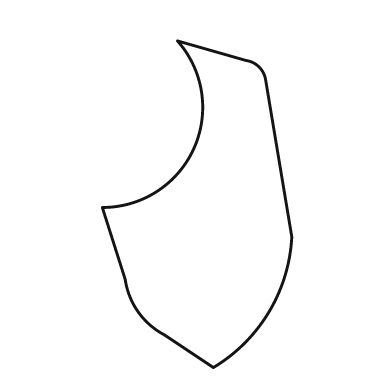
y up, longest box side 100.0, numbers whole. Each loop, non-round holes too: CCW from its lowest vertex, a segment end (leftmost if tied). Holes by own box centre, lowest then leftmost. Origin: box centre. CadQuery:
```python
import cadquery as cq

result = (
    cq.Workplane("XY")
    .moveTo(5.0, -50.0)
    .threePointArc((22.0, -33.0), (29.0, -10.0))
    .lineTo(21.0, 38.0)
    .threePointArc((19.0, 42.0), (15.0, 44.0))
    .lineTo(-6.0, 50.0)
    .threePointArc((-1.0, 17.0), (-29.0, -1.0))
    .lineTo(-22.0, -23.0)
    .threePointArc((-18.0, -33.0), (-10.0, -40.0))
    .close()
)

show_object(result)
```